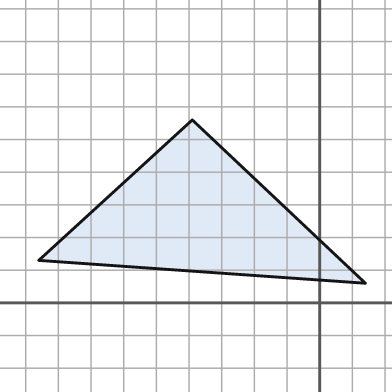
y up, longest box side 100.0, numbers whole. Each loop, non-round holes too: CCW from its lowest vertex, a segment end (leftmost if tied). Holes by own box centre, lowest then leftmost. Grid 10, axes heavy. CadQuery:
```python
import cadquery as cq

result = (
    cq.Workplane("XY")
    .moveTo(14.0, 6.0)
    .lineTo(-39.0, 56.0)
    .lineTo(-86.0, 13.0)
    .close()
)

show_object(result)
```